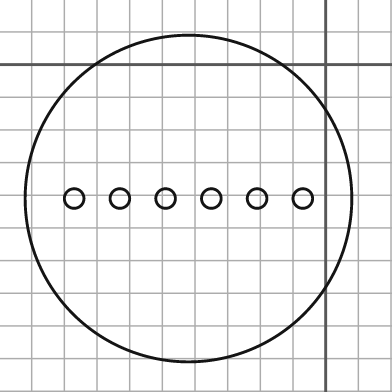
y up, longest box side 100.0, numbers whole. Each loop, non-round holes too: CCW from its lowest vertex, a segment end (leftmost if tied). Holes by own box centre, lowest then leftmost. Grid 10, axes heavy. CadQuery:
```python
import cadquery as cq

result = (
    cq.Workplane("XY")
    .moveTo(-42.0, -41.0)
    .circle(50.0)
    .moveTo(-77.0, -41.0)
    .circle(3.0)
    .moveTo(-63.0, -41.0)
    .circle(3.0)
    .moveTo(-49.0, -41.0)
    .circle(3.0)
    .moveTo(-35.0, -41.0)
    .circle(3.0)
    .moveTo(-21.0, -41.0)
    .circle(3.0)
    .moveTo(-7.0, -41.0)
    .circle(3.0)
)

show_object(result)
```